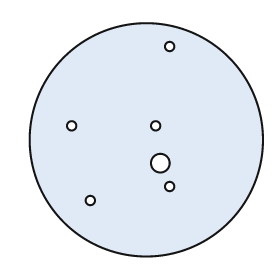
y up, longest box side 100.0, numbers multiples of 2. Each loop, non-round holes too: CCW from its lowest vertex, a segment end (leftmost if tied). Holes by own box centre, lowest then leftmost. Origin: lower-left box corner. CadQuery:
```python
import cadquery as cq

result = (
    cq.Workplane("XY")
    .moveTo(50.0, 50.0)
    .circle(50.0)
    .moveTo(26.0, 24.0)
    .circle(2.0)
    .moveTo(60.0, 30.0)
    .circle(2.0)
    .moveTo(56.0, 40.0)
    .circle(4.0)
    .moveTo(18.0, 56.0)
    .circle(2.0)
    .moveTo(54.0, 56.0)
    .circle(2.0)
    .moveTo(60.0, 90.0)
    .circle(2.0)
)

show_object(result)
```